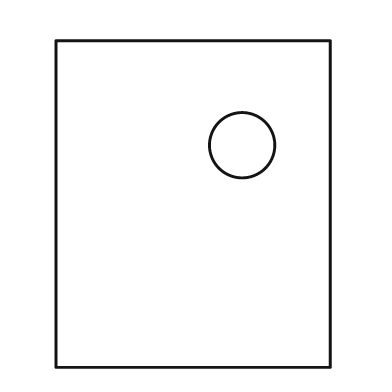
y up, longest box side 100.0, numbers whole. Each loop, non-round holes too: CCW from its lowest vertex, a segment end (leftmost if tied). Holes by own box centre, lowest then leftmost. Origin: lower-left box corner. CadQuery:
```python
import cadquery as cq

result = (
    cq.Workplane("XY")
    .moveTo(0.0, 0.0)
    .lineTo(84.0, 0.0)
    .lineTo(84.0, 100.0)
    .lineTo(0.0, 100.0)
    .close()
    .moveTo(57.0, 68.0)
    .circle(10.0)
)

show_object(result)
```